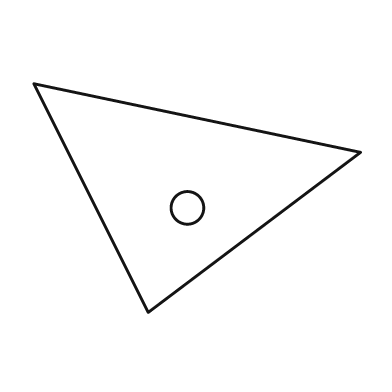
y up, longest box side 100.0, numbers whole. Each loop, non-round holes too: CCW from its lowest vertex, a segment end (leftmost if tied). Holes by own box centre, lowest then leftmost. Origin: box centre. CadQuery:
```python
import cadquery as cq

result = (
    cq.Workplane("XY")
    .moveTo(-15.0, -35.0)
    .lineTo(50.0, 14.0)
    .lineTo(-50.0, 35.0)
    .close()
    .moveTo(-3.0, -3.0)
    .circle(5.0)
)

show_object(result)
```